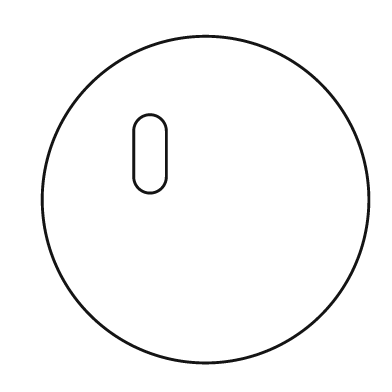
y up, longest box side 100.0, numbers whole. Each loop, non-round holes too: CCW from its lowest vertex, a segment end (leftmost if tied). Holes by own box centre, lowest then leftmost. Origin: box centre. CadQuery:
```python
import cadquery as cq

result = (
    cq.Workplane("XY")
    .moveTo(0.0, 0.0)
    .circle(50.0)
    .moveTo(-22.0, 7.0)
    .threePointArc((-17.0, 2.0), (-12.0, 7.0))
    .lineTo(-12.0, 21.0)
    .threePointArc((-17.0, 26.0), (-22.0, 21.0))
    .close()
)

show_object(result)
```